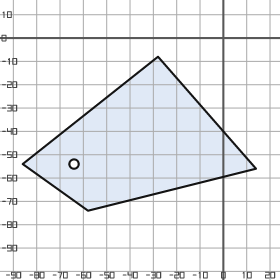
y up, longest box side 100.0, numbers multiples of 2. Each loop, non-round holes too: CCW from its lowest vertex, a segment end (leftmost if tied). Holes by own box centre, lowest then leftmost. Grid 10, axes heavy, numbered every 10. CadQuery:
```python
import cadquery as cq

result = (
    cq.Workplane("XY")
    .moveTo(-58.0, -74.0)
    .lineTo(14.0, -56.0)
    .lineTo(-28.0, -8.0)
    .lineTo(-86.0, -54.0)
    .close()
    .moveTo(-64.0, -54.0)
    .circle(2.0)
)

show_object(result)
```